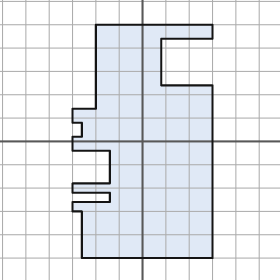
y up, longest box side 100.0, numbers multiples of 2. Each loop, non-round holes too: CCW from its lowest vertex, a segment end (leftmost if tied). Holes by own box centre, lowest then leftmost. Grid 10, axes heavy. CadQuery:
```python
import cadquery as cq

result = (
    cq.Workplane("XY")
    .moveTo(-26.0, -50.0)
    .lineTo(30.0, -50.0)
    .lineTo(30.0, 24.0)
    .lineTo(8.0, 24.0)
    .lineTo(8.0, 44.0)
    .lineTo(30.0, 44.0)
    .lineTo(30.0, 50.0)
    .lineTo(-20.0, 50.0)
    .lineTo(-20.0, 14.0)
    .lineTo(-30.0, 14.0)
    .lineTo(-30.0, 8.0)
    .lineTo(-26.0, 8.0)
    .lineTo(-26.0, 2.0)
    .lineTo(-30.0, 2.0)
    .lineTo(-30.0, -4.0)
    .lineTo(-14.0, -4.0)
    .lineTo(-14.0, -18.0)
    .lineTo(-30.0, -18.0)
    .lineTo(-30.0, -22.0)
    .lineTo(-14.0, -22.0)
    .lineTo(-14.0, -26.0)
    .lineTo(-30.0, -26.0)
    .lineTo(-30.0, -30.0)
    .lineTo(-26.0, -30.0)
    .close()
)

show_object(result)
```